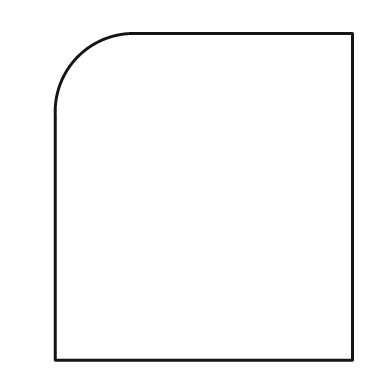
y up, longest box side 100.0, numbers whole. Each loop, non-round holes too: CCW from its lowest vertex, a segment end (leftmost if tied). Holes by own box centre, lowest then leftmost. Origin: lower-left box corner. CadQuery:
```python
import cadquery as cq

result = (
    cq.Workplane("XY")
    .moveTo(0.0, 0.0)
    .lineTo(91.0, 0.0)
    .lineTo(91.0, 100.0)
    .lineTo(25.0, 100.0)
    .threePointArc((7.0, 93.0), (0.0, 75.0))
    .close()
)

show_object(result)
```